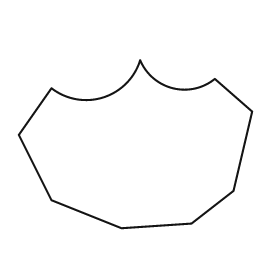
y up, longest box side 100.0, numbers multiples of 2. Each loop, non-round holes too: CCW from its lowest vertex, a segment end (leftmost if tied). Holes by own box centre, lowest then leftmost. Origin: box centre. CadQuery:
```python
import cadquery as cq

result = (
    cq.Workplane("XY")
    .moveTo(-6.0, -36.0)
    .lineTo(24.0, -34.0)
    .lineTo(42.0, -20.0)
    .lineTo(50.0, 14.0)
    .lineTo(34.0, 28.0)
    .threePointArc((16.0, 24.0), (2.0, 36.0))
    .threePointArc((-14.0, 20.0), (-36.0, 24.0))
    .lineTo(-50.0, 4.0)
    .lineTo(-36.0, -24.0)
    .close()
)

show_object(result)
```